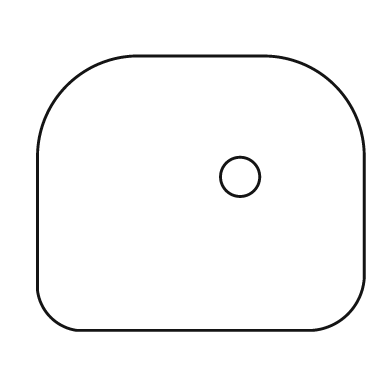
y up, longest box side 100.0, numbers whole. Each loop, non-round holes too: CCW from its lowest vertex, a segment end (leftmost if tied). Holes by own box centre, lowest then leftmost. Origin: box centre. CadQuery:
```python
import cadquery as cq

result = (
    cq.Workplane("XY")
    .moveTo(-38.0, -42.0)
    .lineTo(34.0, -42.0)
    .threePointArc((45.0, -37.0), (50.0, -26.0))
    .lineTo(50.0, 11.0)
    .threePointArc((41.0, 33.0), (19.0, 42.0))
    .lineTo(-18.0, 42.0)
    .threePointArc((-41.0, 33.0), (-50.0, 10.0))
    .lineTo(-50.0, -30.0)
    .threePointArc((-46.0, -38.0), (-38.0, -42.0))
    .close()
    .moveTo(12.0, 5.0)
    .circle(6.0)
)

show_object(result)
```